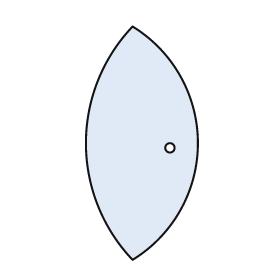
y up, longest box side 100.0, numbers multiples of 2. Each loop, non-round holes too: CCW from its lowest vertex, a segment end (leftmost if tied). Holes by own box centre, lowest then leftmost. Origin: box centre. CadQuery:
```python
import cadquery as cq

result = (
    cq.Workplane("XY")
    .moveTo(-4.0, -50.0)
    .threePointArc((24.0, 0.0), (-4.0, 50.0))
    .threePointArc((-24.0, 0.0), (-4.0, -50.0))
    .close()
    .moveTo(12.0, -2.0)
    .circle(2.0)
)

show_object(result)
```